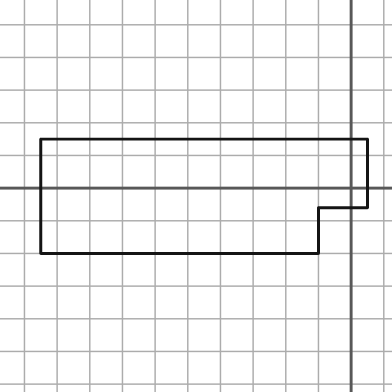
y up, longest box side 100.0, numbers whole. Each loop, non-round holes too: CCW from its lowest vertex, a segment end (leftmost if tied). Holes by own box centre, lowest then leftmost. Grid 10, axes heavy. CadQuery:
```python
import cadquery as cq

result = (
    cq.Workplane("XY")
    .moveTo(-95.0, -20.0)
    .lineTo(-10.0, -20.0)
    .lineTo(-10.0, -6.0)
    .lineTo(5.0, -6.0)
    .lineTo(5.0, 15.0)
    .lineTo(-95.0, 15.0)
    .close()
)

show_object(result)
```